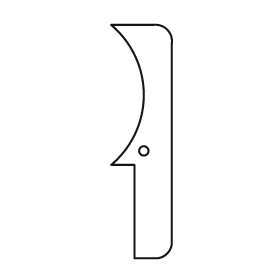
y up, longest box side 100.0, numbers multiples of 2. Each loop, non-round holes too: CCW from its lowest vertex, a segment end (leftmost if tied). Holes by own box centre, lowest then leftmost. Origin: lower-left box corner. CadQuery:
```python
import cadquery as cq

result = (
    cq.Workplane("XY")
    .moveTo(10.0, 0.0)
    .lineTo(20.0, 0.0)
    .threePointArc((24.0, 2.0), (26.0, 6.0))
    .lineTo(26.0, 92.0)
    .threePointArc((24.0, 98.0), (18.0, 100.0))
    .lineTo(0.0, 100.0)
    .threePointArc((14.0, 70.0), (0.0, 40.0))
    .lineTo(10.0, 40.0)
    .close()
    .moveTo(14.0, 46.0)
    .circle(2.0)
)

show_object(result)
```